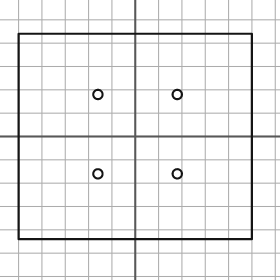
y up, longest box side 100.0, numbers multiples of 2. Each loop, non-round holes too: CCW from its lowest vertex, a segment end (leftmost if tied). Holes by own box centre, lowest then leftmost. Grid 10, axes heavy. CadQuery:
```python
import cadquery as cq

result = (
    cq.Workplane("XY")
    .moveTo(-50.0, -44.0)
    .lineTo(50.0, -44.0)
    .lineTo(50.0, 44.0)
    .lineTo(-50.0, 44.0)
    .close()
    .moveTo(-16.0, -16.0)
    .circle(2.0)
    .moveTo(18.0, -16.0)
    .circle(2.0)
    .moveTo(-16.0, 18.0)
    .circle(2.0)
    .moveTo(18.0, 18.0)
    .circle(2.0)
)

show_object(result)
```